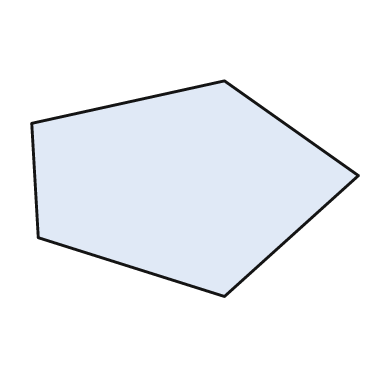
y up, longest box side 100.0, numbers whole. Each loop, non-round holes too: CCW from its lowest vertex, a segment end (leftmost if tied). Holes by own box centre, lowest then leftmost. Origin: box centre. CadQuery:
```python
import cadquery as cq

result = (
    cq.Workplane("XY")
    .moveTo(9.0, -33.0)
    .lineTo(50.0, 4.0)
    .lineTo(9.0, 33.0)
    .lineTo(-50.0, 20.0)
    .lineTo(-48.0, -15.0)
    .close()
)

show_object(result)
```